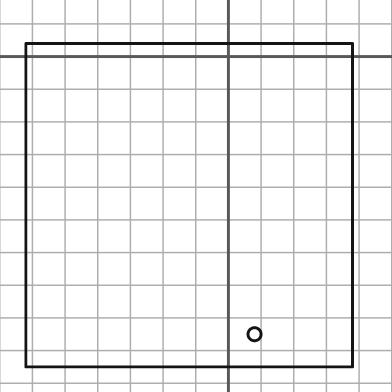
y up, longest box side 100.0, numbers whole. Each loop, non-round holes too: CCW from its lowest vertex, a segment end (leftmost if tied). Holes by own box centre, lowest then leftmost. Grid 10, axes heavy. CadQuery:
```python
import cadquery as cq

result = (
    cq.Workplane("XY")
    .moveTo(-62.0, -95.0)
    .lineTo(38.0, -95.0)
    .lineTo(38.0, 4.0)
    .lineTo(-62.0, 4.0)
    .close()
    .moveTo(8.0, -85.0)
    .circle(2.0)
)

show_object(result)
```